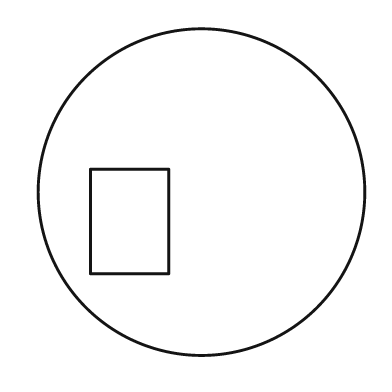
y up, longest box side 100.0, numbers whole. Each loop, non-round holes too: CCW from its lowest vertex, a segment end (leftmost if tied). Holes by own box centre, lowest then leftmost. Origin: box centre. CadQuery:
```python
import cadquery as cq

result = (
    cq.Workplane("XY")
    .moveTo(0.0, 0.0)
    .circle(50.0)
    .moveTo(-34.0, -25.0)
    .lineTo(-10.0, -25.0)
    .lineTo(-10.0, 7.0)
    .lineTo(-34.0, 7.0)
    .close()
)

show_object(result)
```